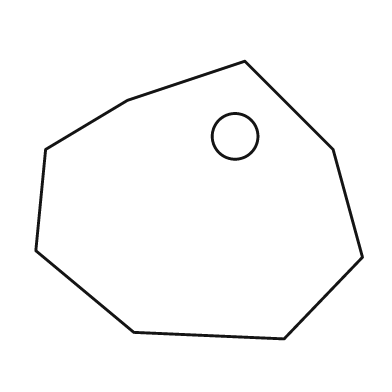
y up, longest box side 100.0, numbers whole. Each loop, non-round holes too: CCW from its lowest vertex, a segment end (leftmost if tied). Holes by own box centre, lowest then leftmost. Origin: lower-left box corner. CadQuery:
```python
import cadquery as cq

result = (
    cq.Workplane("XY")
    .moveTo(76.0, 0.0)
    .lineTo(100.0, 25.0)
    .lineTo(91.0, 58.0)
    .lineTo(64.0, 85.0)
    .lineTo(28.0, 73.0)
    .lineTo(3.0, 58.0)
    .lineTo(0.0, 27.0)
    .lineTo(30.0, 2.0)
    .close()
    .moveTo(61.0, 62.0)
    .circle(7.0)
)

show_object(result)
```